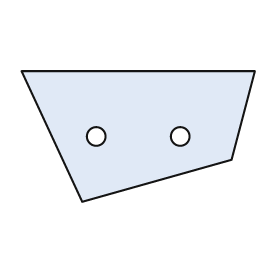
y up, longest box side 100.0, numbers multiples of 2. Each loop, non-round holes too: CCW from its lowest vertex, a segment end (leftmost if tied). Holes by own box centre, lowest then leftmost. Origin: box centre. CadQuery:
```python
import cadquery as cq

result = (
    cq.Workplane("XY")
    .moveTo(-24.0, -28.0)
    .lineTo(40.0, -10.0)
    .lineTo(50.0, 28.0)
    .lineTo(-50.0, 28.0)
    .close()
    .moveTo(-18.0, 0.0)
    .circle(4.0)
    .moveTo(18.0, 0.0)
    .circle(4.0)
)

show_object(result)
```